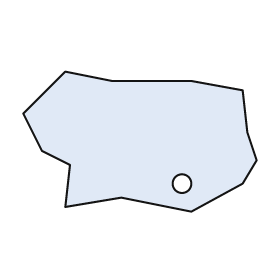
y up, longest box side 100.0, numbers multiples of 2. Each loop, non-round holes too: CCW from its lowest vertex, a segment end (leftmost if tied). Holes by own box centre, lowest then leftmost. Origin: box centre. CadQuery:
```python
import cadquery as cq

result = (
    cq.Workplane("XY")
    .moveTo(22.0, -30.0)
    .lineTo(44.0, -18.0)
    .lineTo(50.0, -8.0)
    .lineTo(46.0, 4.0)
    .lineTo(44.0, 22.0)
    .lineTo(22.0, 26.0)
    .lineTo(-12.0, 26.0)
    .lineTo(-32.0, 30.0)
    .lineTo(-50.0, 12.0)
    .lineTo(-42.0, -4.0)
    .lineTo(-30.0, -10.0)
    .lineTo(-32.0, -28.0)
    .lineTo(-8.0, -24.0)
    .close()
    .moveTo(18.0, -18.0)
    .circle(4.0)
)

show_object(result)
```